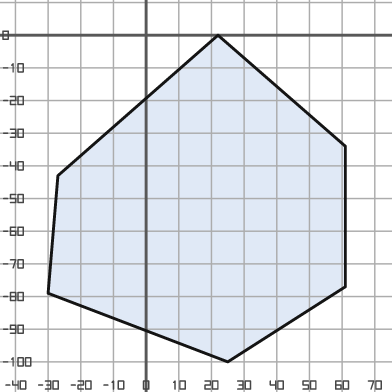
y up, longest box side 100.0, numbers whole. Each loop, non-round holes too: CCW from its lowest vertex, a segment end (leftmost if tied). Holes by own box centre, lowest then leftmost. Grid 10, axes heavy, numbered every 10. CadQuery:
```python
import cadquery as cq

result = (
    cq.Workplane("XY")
    .moveTo(25.0, -100.0)
    .lineTo(61.0, -77.0)
    .lineTo(61.0, -34.0)
    .lineTo(22.0, 0.0)
    .lineTo(-27.0, -43.0)
    .lineTo(-30.0, -79.0)
    .close()
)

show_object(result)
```